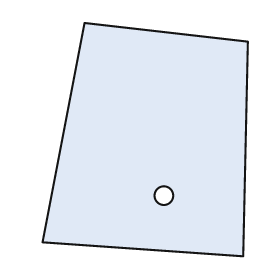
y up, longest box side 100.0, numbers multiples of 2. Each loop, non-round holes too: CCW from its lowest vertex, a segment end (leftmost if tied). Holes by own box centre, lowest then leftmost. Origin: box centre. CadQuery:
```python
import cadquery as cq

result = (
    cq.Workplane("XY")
    .moveTo(42.0, -50.0)
    .lineTo(44.0, 42.0)
    .lineTo(-26.0, 50.0)
    .lineTo(-44.0, -44.0)
    .close()
    .moveTo(8.0, -24.0)
    .circle(4.0)
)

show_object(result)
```